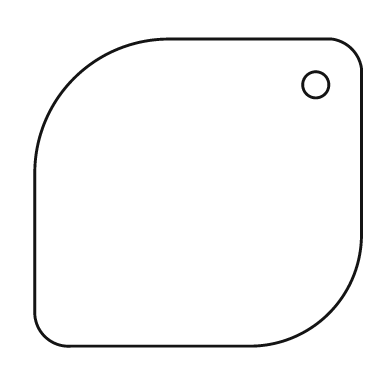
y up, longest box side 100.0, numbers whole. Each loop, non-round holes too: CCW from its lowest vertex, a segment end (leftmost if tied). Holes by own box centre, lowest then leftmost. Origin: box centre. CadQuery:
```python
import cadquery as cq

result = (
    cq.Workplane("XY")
    .moveTo(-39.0, -47.0)
    .lineTo(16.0, -47.0)
    .threePointArc((40.0, -37.0), (50.0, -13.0))
    .lineTo(50.0, 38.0)
    .threePointArc((47.0, 44.0), (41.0, 47.0))
    .lineTo(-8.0, 47.0)
    .threePointArc((-38.0, 35.0), (-50.0, 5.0))
    .lineTo(-50.0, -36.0)
    .threePointArc((-47.0, -44.0), (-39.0, -47.0))
    .close()
    .moveTo(36.0, 33.0)
    .circle(4.0)
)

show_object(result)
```